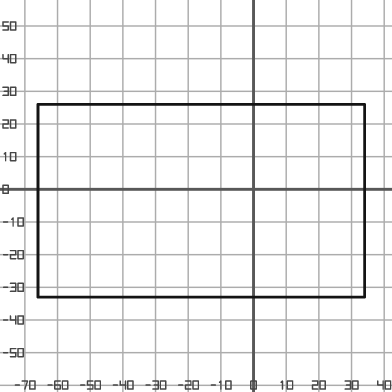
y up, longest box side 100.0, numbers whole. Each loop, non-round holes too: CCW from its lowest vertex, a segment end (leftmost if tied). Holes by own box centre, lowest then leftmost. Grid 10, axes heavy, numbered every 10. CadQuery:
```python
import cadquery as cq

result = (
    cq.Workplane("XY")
    .moveTo(-66.0, -33.0)
    .lineTo(34.0, -33.0)
    .lineTo(34.0, 26.0)
    .lineTo(-66.0, 26.0)
    .close()
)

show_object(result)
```